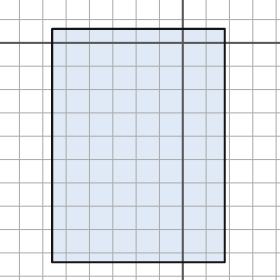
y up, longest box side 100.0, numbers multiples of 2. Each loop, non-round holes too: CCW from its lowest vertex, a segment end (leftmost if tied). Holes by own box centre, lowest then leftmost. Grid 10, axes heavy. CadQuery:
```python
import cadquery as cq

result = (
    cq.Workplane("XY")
    .moveTo(-56.0, -94.0)
    .lineTo(18.0, -94.0)
    .lineTo(18.0, 6.0)
    .lineTo(-56.0, 6.0)
    .close()
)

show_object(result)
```